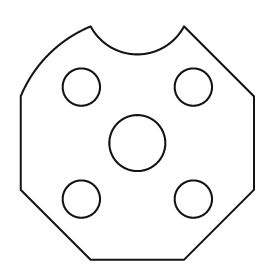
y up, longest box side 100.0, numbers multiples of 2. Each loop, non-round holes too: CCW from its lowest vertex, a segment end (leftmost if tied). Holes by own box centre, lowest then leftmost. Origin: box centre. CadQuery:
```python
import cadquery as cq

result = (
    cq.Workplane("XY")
    .moveTo(-20.0, -50.0)
    .lineTo(20.0, -50.0)
    .lineTo(50.0, -20.0)
    .lineTo(50.0, 20.0)
    .lineTo(20.0, 50.0)
    .threePointArc((0.0, 38.0), (-20.0, 50.0))
    .threePointArc((-38.0, 38.0), (-50.0, 20.0))
    .lineTo(-50.0, -20.0)
    .close()
    .moveTo(-24.0, -24.0)
    .circle(8.0)
    .moveTo(24.0, -24.0)
    .circle(8.0)
    .moveTo(0.0, 0.0)
    .circle(12.0)
    .moveTo(-24.0, 24.0)
    .circle(8.0)
    .moveTo(24.0, 24.0)
    .circle(8.0)
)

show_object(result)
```